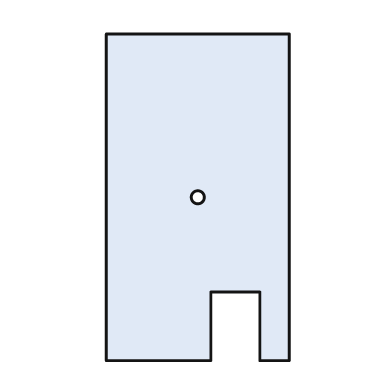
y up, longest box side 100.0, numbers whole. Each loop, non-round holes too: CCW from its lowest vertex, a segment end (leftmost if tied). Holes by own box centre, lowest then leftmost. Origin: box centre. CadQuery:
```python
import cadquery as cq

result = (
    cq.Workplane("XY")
    .moveTo(-28.0, -50.0)
    .lineTo(4.0, -50.0)
    .lineTo(4.0, -29.0)
    .lineTo(19.0, -29.0)
    .lineTo(19.0, -50.0)
    .lineTo(28.0, -50.0)
    .lineTo(28.0, 50.0)
    .lineTo(-28.0, 50.0)
    .close()
    .moveTo(0.0, 0.0)
    .circle(2.0)
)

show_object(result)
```